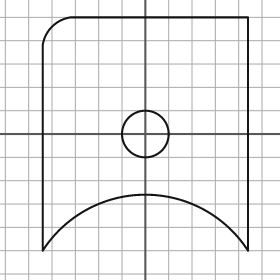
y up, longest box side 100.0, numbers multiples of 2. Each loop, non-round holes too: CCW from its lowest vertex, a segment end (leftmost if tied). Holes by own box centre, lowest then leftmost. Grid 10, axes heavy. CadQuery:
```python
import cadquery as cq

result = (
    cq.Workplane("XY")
    .moveTo(-44.0, -50.0)
    .threePointArc((0.0, -26.0), (44.0, -50.0))
    .lineTo(44.0, 50.0)
    .lineTo(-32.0, 50.0)
    .threePointArc((-40.0, 46.0), (-44.0, 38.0))
    .close()
    .moveTo(0.0, 0.0)
    .circle(10.0)
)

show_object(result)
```